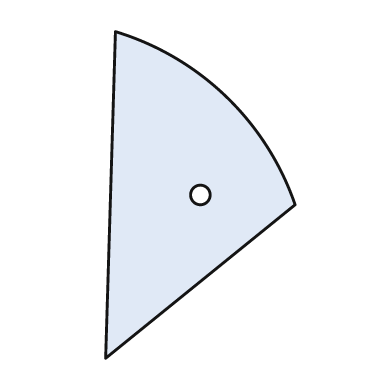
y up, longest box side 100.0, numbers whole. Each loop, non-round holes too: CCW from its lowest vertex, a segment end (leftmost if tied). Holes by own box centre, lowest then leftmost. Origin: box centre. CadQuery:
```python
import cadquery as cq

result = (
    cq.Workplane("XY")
    .moveTo(-29.0, -50.0)
    .lineTo(29.0, -3.0)
    .threePointArc((8.0, 30.0), (-26.0, 50.0))
    .close()
    .moveTo(0.0, 0.0)
    .circle(3.0)
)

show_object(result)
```